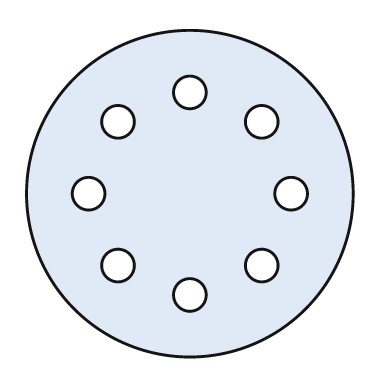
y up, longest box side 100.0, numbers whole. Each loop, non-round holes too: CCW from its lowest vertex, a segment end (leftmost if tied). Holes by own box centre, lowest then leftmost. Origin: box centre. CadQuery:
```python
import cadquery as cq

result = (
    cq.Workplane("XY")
    .moveTo(0.0, 0.0)
    .circle(50.0)
    .moveTo(0.0, -31.0)
    .circle(5.0)
    .moveTo(-22.0, -22.0)
    .circle(5.0)
    .moveTo(22.0, -22.0)
    .circle(5.0)
    .moveTo(-31.0, 0.0)
    .circle(5.0)
    .moveTo(31.0, 0.0)
    .circle(5.0)
    .moveTo(-22.0, 22.0)
    .circle(5.0)
    .moveTo(22.0, 22.0)
    .circle(5.0)
    .moveTo(0.0, 31.0)
    .circle(5.0)
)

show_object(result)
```